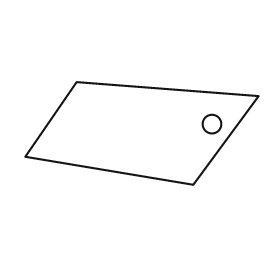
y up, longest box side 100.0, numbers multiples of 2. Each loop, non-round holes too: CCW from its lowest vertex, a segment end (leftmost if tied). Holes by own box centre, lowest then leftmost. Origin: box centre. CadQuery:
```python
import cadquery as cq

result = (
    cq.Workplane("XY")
    .moveTo(22.0, -22.0)
    .lineTo(50.0, 16.0)
    .lineTo(-28.0, 22.0)
    .lineTo(-50.0, -10.0)
    .close()
    .moveTo(30.0, 4.0)
    .circle(4.0)
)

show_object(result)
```